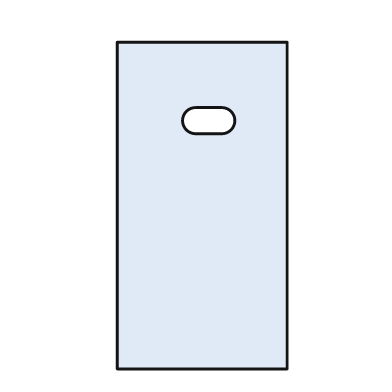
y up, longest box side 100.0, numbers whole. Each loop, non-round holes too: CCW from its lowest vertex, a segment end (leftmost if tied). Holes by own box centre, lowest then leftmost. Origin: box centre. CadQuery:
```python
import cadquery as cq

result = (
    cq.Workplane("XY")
    .moveTo(-26.0, -50.0)
    .lineTo(26.0, -50.0)
    .lineTo(26.0, 50.0)
    .lineTo(-26.0, 50.0)
    .close()
    .moveTo(-2.0, 22.0)
    .lineTo(6.0, 22.0)
    .threePointArc((10.0, 26.0), (6.0, 30.0))
    .lineTo(-2.0, 30.0)
    .threePointArc((-6.0, 26.0), (-2.0, 22.0))
    .close()
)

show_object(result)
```